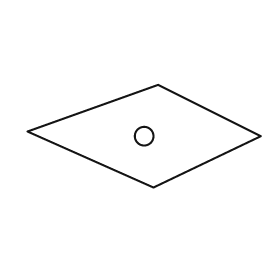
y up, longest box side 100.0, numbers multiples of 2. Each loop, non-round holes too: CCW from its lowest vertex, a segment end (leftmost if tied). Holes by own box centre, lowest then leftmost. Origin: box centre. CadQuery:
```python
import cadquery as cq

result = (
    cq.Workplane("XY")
    .moveTo(4.0, -22.0)
    .lineTo(50.0, 0.0)
    .lineTo(6.0, 22.0)
    .lineTo(-50.0, 2.0)
    .close()
    .moveTo(0.0, 0.0)
    .circle(4.0)
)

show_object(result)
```